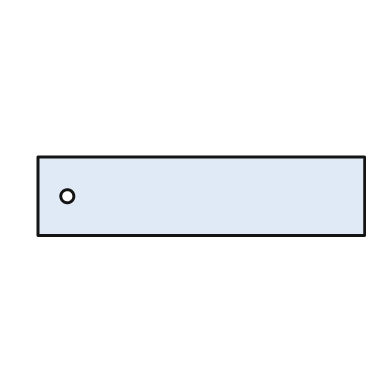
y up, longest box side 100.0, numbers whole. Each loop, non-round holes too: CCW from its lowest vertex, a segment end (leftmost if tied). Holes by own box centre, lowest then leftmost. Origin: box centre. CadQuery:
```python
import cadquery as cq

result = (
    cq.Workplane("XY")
    .moveTo(-50.0, -12.0)
    .lineTo(50.0, -12.0)
    .lineTo(50.0, 12.0)
    .lineTo(-50.0, 12.0)
    .close()
    .moveTo(-41.0, 0.0)
    .circle(2.0)
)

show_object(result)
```